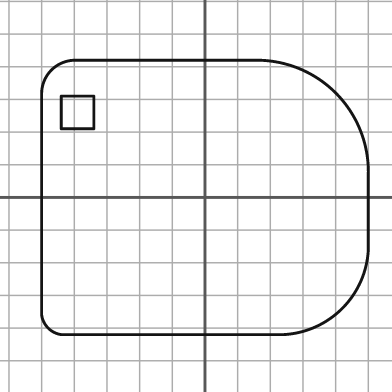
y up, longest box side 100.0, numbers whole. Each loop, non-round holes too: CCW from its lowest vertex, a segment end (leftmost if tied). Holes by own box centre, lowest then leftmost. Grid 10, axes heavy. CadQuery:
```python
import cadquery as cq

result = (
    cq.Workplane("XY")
    .moveTo(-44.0, -42.0)
    .lineTo(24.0, -42.0)
    .threePointArc((42.0, -34.0), (50.0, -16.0))
    .lineTo(50.0, 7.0)
    .threePointArc((40.0, 32.0), (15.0, 42.0))
    .lineTo(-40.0, 42.0)
    .threePointArc((-47.0, 39.0), (-50.0, 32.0))
    .lineTo(-50.0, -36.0)
    .threePointArc((-48.0, -40.0), (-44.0, -42.0))
    .close()
    .moveTo(-44.0, 21.0)
    .lineTo(-34.0, 21.0)
    .lineTo(-34.0, 31.0)
    .lineTo(-44.0, 31.0)
    .close()
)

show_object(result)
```